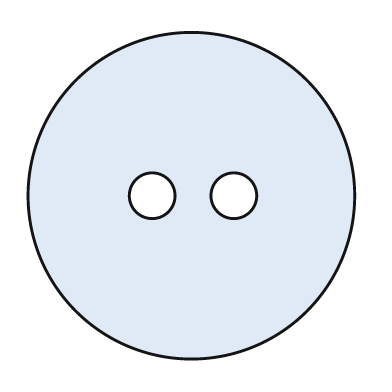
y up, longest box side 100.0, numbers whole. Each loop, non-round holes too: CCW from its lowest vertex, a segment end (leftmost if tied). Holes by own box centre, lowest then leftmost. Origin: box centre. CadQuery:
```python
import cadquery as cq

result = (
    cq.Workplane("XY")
    .moveTo(0.0, 0.0)
    .circle(50.0)
    .moveTo(-12.0, 0.0)
    .circle(7.0)
    .moveTo(13.0, 0.0)
    .circle(7.0)
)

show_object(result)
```